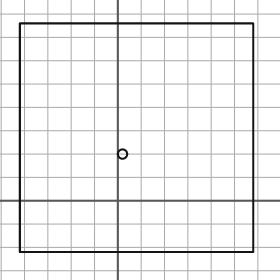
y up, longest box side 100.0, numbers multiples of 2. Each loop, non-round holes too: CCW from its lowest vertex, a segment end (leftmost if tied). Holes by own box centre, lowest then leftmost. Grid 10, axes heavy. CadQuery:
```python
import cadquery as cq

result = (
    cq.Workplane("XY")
    .moveTo(-42.0, -22.0)
    .lineTo(58.0, -22.0)
    .lineTo(58.0, 76.0)
    .lineTo(-42.0, 76.0)
    .close()
    .moveTo(2.0, 20.0)
    .circle(2.0)
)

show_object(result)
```